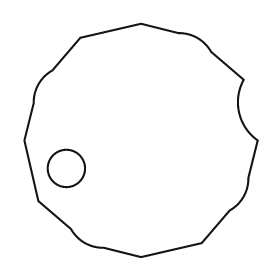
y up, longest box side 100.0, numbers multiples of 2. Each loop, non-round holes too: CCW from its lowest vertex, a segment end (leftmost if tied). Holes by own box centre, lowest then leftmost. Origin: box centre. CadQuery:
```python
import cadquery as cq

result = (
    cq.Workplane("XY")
    .moveTo(0.0, -50.0)
    .lineTo(26.0, -44.0)
    .lineTo(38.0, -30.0)
    .threePointArc((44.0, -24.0), (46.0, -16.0))
    .lineTo(50.0, 0.0)
    .threePointArc((42.0, 12.0), (44.0, 26.0))
    .lineTo(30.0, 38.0)
    .threePointArc((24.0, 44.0), (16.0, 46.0))
    .lineTo(0.0, 50.0)
    .lineTo(-26.0, 44.0)
    .lineTo(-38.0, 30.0)
    .threePointArc((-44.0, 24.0), (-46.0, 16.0))
    .lineTo(-50.0, 0.0)
    .lineTo(-44.0, -26.0)
    .lineTo(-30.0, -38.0)
    .threePointArc((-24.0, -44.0), (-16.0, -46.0))
    .close()
    .moveTo(-32.0, -12.0)
    .circle(8.0)
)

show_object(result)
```